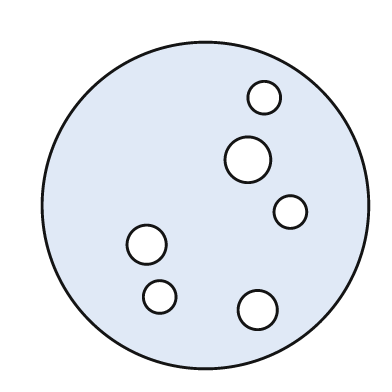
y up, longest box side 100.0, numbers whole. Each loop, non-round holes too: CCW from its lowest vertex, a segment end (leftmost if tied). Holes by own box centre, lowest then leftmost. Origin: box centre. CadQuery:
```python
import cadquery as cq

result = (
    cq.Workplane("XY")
    .moveTo(0.0, 0.0)
    .circle(50.0)
    .moveTo(16.0, -32.0)
    .circle(6.0)
    .moveTo(-14.0, -28.0)
    .circle(5.0)
    .moveTo(-18.0, -12.0)
    .circle(6.0)
    .moveTo(26.0, -2.0)
    .circle(5.0)
    .moveTo(13.0, 14.0)
    .circle(7.0)
    .moveTo(18.0, 33.0)
    .circle(5.0)
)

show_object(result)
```